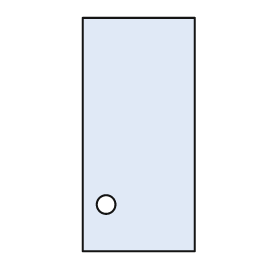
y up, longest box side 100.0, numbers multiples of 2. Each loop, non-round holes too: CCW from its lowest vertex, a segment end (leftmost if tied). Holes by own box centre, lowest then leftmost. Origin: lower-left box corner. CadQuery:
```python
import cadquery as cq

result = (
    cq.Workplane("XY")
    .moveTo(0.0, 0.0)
    .lineTo(48.0, 0.0)
    .lineTo(48.0, 100.0)
    .lineTo(0.0, 100.0)
    .close()
    .moveTo(10.0, 20.0)
    .circle(4.0)
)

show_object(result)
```